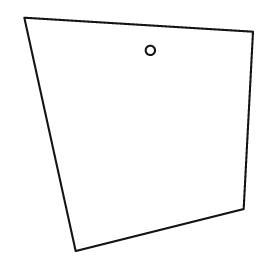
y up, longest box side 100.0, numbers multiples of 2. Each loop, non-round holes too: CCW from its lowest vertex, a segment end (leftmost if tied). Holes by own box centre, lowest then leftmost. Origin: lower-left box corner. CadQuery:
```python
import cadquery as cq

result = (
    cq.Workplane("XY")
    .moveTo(22.0, 0.0)
    .lineTo(94.0, 18.0)
    .lineTo(98.0, 94.0)
    .lineTo(0.0, 100.0)
    .close()
    .moveTo(54.0, 86.0)
    .circle(2.0)
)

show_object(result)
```